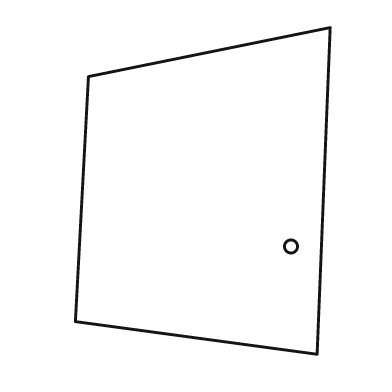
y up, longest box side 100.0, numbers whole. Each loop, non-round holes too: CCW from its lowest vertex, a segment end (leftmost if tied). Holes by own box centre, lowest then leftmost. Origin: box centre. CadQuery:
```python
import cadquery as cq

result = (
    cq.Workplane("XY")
    .moveTo(35.0, -50.0)
    .lineTo(39.0, 50.0)
    .lineTo(-35.0, 35.0)
    .lineTo(-39.0, -40.0)
    .close()
    .moveTo(27.0, -17.0)
    .circle(2.0)
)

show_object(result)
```